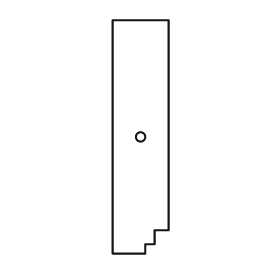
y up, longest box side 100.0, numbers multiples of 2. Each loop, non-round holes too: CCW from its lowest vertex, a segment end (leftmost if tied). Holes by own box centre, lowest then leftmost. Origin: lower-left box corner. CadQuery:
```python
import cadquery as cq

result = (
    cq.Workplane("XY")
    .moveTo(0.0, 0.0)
    .lineTo(14.0, 0.0)
    .lineTo(14.0, 4.0)
    .lineTo(18.0, 4.0)
    .lineTo(18.0, 10.0)
    .lineTo(24.0, 10.0)
    .lineTo(24.0, 100.0)
    .lineTo(0.0, 100.0)
    .close()
    .moveTo(12.0, 50.0)
    .circle(2.0)
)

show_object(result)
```